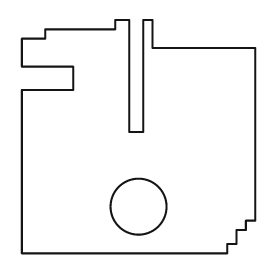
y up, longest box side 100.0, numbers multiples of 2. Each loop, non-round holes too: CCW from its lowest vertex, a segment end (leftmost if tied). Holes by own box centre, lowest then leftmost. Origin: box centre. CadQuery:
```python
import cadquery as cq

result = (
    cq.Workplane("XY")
    .moveTo(-50.0, -50.0)
    .lineTo(38.0, -50.0)
    .lineTo(38.0, -46.0)
    .lineTo(42.0, -46.0)
    .lineTo(42.0, -40.0)
    .lineTo(46.0, -40.0)
    .lineTo(46.0, -36.0)
    .lineTo(50.0, -36.0)
    .lineTo(50.0, 38.0)
    .lineTo(6.0, 38.0)
    .lineTo(6.0, 50.0)
    .lineTo(2.0, 50.0)
    .lineTo(2.0, 2.0)
    .lineTo(-4.0, 2.0)
    .lineTo(-4.0, 50.0)
    .lineTo(-10.0, 50.0)
    .lineTo(-10.0, 46.0)
    .lineTo(-40.0, 46.0)
    .lineTo(-40.0, 42.0)
    .lineTo(-50.0, 42.0)
    .lineTo(-50.0, 30.0)
    .lineTo(-28.0, 30.0)
    .lineTo(-28.0, 20.0)
    .lineTo(-50.0, 20.0)
    .close()
    .moveTo(0.0, -30.0)
    .circle(12.0)
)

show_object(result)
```